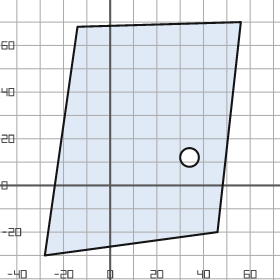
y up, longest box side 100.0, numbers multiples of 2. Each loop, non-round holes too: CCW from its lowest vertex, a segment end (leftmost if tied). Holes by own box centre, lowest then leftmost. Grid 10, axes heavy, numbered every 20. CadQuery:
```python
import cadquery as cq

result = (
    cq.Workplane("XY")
    .moveTo(-28.0, -30.0)
    .lineTo(46.0, -20.0)
    .lineTo(56.0, 70.0)
    .lineTo(-14.0, 68.0)
    .close()
    .moveTo(34.0, 12.0)
    .circle(4.0)
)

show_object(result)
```